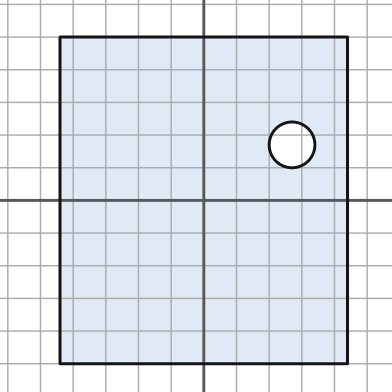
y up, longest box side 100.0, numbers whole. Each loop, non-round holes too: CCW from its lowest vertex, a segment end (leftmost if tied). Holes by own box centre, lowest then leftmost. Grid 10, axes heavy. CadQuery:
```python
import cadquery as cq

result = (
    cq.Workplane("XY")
    .moveTo(-44.0, -50.0)
    .lineTo(44.0, -50.0)
    .lineTo(44.0, 50.0)
    .lineTo(-44.0, 50.0)
    .close()
    .moveTo(27.0, 17.0)
    .circle(7.0)
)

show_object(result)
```